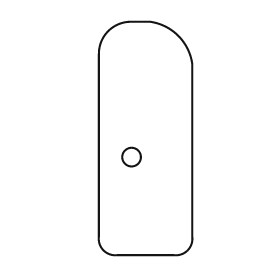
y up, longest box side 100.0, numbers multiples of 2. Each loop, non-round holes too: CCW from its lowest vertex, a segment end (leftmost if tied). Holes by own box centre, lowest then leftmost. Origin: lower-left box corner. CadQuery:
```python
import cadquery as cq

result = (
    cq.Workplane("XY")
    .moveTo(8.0, 0.0)
    .lineTo(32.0, 0.0)
    .threePointArc((38.0, 2.0), (40.0, 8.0))
    .lineTo(40.0, 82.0)
    .threePointArc((34.0, 94.0), (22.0, 100.0))
    .lineTo(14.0, 100.0)
    .threePointArc((4.0, 96.0), (0.0, 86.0))
    .lineTo(0.0, 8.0)
    .threePointArc((2.0, 2.0), (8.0, 0.0))
    .close()
    .moveTo(14.0, 42.0)
    .circle(4.0)
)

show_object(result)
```